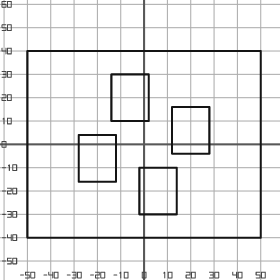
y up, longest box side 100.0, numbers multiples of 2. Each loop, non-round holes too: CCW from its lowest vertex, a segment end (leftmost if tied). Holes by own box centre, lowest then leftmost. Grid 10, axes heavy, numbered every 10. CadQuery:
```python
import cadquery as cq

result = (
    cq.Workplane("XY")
    .moveTo(-50.0, -40.0)
    .lineTo(50.0, -40.0)
    .lineTo(50.0, 40.0)
    .lineTo(-50.0, 40.0)
    .close()
    .moveTo(-2.0, -30.0)
    .lineTo(14.0, -30.0)
    .lineTo(14.0, -10.0)
    .lineTo(-2.0, -10.0)
    .close()
    .moveTo(-28.0, -16.0)
    .lineTo(-12.0, -16.0)
    .lineTo(-12.0, 4.0)
    .lineTo(-28.0, 4.0)
    .close()
    .moveTo(12.0, -4.0)
    .lineTo(28.0, -4.0)
    .lineTo(28.0, 16.0)
    .lineTo(12.0, 16.0)
    .close()
    .moveTo(-14.0, 10.0)
    .lineTo(2.0, 10.0)
    .lineTo(2.0, 30.0)
    .lineTo(-14.0, 30.0)
    .close()
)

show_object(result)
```